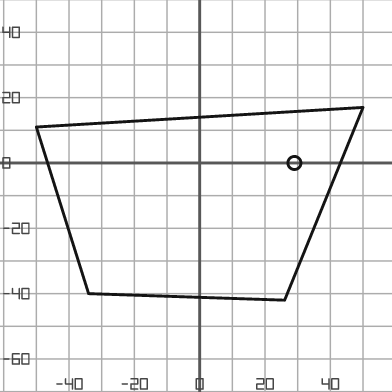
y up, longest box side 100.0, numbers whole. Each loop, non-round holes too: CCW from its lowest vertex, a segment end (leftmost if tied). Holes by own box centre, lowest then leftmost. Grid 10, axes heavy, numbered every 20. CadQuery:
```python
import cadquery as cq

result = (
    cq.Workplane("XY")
    .moveTo(26.0, -42.0)
    .lineTo(50.0, 17.0)
    .lineTo(-50.0, 11.0)
    .lineTo(-34.0, -40.0)
    .close()
    .moveTo(29.0, 0.0)
    .circle(2.0)
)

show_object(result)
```